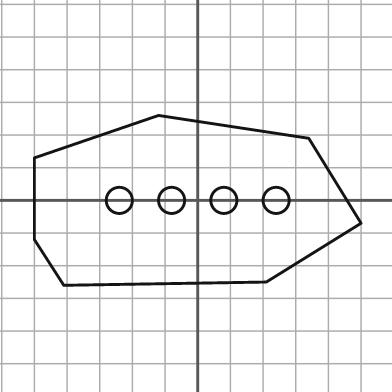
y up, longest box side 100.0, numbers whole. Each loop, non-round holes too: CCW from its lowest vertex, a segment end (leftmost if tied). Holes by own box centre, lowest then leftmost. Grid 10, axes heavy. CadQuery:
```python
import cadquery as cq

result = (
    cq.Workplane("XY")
    .moveTo(-41.0, -26.0)
    .lineTo(21.0, -25.0)
    .lineTo(50.0, -7.0)
    .lineTo(34.0, 19.0)
    .lineTo(-12.0, 26.0)
    .lineTo(-50.0, 13.0)
    .lineTo(-50.0, -12.0)
    .close()
    .moveTo(-24.0, 0.0)
    .circle(4.0)
    .moveTo(-8.0, 0.0)
    .circle(4.0)
    .moveTo(8.0, 0.0)
    .circle(4.0)
    .moveTo(24.0, 0.0)
    .circle(4.0)
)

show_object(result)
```